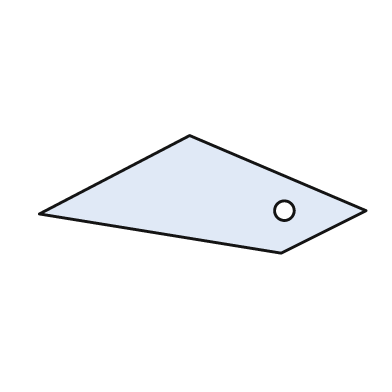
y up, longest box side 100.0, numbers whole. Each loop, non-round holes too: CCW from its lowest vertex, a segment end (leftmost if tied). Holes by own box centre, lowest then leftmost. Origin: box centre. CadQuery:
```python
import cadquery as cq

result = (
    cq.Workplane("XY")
    .moveTo(24.0, -18.0)
    .lineTo(50.0, -5.0)
    .lineTo(-4.0, 18.0)
    .lineTo(-50.0, -6.0)
    .close()
    .moveTo(25.0, -5.0)
    .circle(3.0)
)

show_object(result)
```